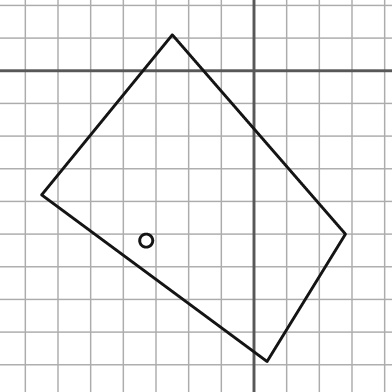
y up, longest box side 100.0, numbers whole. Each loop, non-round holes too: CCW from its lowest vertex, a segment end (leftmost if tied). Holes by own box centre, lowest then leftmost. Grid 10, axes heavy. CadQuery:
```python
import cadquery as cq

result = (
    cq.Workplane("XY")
    .moveTo(4.0, -89.0)
    .lineTo(28.0, -50.0)
    .lineTo(-25.0, 11.0)
    .lineTo(-65.0, -38.0)
    .close()
    .moveTo(-33.0, -52.0)
    .circle(2.0)
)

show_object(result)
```